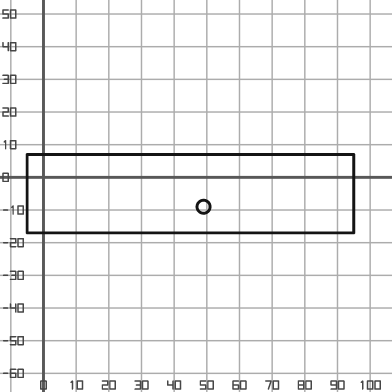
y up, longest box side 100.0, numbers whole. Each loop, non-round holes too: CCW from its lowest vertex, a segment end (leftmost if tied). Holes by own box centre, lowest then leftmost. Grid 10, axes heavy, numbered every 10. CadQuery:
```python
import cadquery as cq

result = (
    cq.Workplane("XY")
    .moveTo(-5.0, -17.0)
    .lineTo(95.0, -17.0)
    .lineTo(95.0, 7.0)
    .lineTo(-5.0, 7.0)
    .close()
    .moveTo(49.0, -9.0)
    .circle(2.0)
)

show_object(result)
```